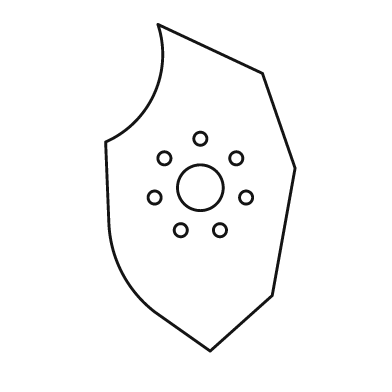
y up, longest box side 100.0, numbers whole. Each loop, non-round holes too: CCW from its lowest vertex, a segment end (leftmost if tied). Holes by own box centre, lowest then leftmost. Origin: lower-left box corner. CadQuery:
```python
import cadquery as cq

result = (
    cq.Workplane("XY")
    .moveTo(32.0, 0.0)
    .lineTo(51.0, 17.0)
    .lineTo(58.0, 56.0)
    .lineTo(48.0, 85.0)
    .lineTo(16.0, 100.0)
    .threePointArc((15.0, 79.0), (0.0, 64.0))
    .lineTo(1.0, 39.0)
    .threePointArc((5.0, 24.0), (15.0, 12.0))
    .close()
    .moveTo(23.0, 37.0)
    .circle(2.0)
    .moveTo(35.0, 37.0)
    .circle(2.0)
    .moveTo(15.0, 47.0)
    .circle(2.0)
    .moveTo(43.0, 47.0)
    .circle(2.0)
    .moveTo(29.0, 50.0)
    .circle(7.0)
    .moveTo(18.0, 59.0)
    .circle(2.0)
    .moveTo(40.0, 59.0)
    .circle(2.0)
    .moveTo(29.0, 65.0)
    .circle(2.0)
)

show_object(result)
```